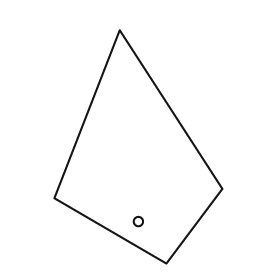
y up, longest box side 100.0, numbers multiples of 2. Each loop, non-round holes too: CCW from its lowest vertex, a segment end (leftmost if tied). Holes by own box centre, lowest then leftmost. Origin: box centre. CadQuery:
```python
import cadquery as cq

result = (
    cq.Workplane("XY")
    .moveTo(12.0, -50.0)
    .lineTo(36.0, -18.0)
    .lineTo(-8.0, 50.0)
    .lineTo(-36.0, -22.0)
    .close()
    .moveTo(0.0, -32.0)
    .circle(2.0)
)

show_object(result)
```